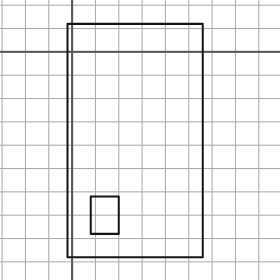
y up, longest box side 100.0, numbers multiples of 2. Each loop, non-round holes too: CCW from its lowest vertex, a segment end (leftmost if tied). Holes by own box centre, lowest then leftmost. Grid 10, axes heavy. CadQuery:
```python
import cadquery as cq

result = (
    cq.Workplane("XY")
    .moveTo(-2.0, -88.0)
    .lineTo(56.0, -88.0)
    .lineTo(56.0, 12.0)
    .lineTo(-2.0, 12.0)
    .close()
    .moveTo(8.0, -78.0)
    .lineTo(20.0, -78.0)
    .lineTo(20.0, -62.0)
    .lineTo(8.0, -62.0)
    .close()
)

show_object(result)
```